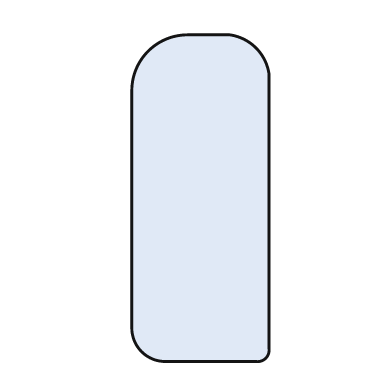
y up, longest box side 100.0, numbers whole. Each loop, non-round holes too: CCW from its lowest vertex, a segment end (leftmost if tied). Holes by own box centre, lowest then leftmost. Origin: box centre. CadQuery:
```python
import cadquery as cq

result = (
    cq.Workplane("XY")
    .moveTo(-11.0, -50.0)
    .lineTo(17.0, -50.0)
    .threePointArc((20.0, -49.0), (21.0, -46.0))
    .lineTo(21.0, 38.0)
    .threePointArc((17.0, 46.0), (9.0, 50.0))
    .lineTo(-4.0, 50.0)
    .threePointArc((-16.0, 45.0), (-21.0, 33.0))
    .lineTo(-21.0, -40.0)
    .threePointArc((-18.0, -47.0), (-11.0, -50.0))
    .close()
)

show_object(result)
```